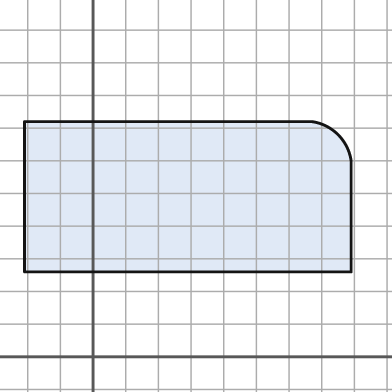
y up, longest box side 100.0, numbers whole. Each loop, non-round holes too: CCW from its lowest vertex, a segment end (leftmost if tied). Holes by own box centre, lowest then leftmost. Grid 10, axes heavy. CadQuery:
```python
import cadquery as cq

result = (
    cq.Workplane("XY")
    .moveTo(-21.0, 26.0)
    .lineTo(79.0, 26.0)
    .lineTo(79.0, 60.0)
    .threePointArc((75.0, 68.0), (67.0, 72.0))
    .lineTo(-21.0, 72.0)
    .close()
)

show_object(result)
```